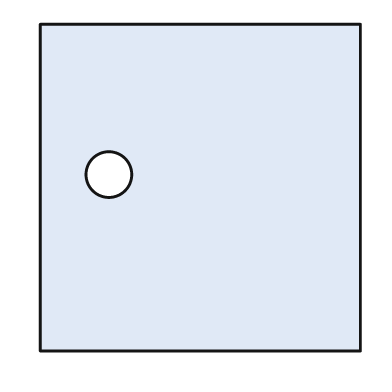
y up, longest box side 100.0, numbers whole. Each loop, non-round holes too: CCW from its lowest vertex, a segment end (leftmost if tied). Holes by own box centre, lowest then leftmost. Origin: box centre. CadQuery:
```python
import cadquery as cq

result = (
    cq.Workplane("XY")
    .moveTo(-49.0, -50.0)
    .lineTo(49.0, -50.0)
    .lineTo(49.0, 50.0)
    .lineTo(-49.0, 50.0)
    .close()
    .moveTo(-28.0, 4.0)
    .circle(7.0)
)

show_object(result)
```